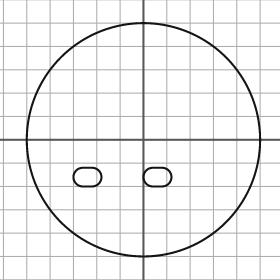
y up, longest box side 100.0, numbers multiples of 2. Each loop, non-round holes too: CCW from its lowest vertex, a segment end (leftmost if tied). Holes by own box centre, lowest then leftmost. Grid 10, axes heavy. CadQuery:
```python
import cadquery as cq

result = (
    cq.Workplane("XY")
    .moveTo(0.0, 0.0)
    .circle(50.0)
    .moveTo(-26.0, -20.0)
    .lineTo(-22.0, -20.0)
    .threePointArc((-18.0, -16.0), (-22.0, -12.0))
    .lineTo(-26.0, -12.0)
    .threePointArc((-30.0, -16.0), (-26.0, -20.0))
    .close()
    .moveTo(4.0, -20.0)
    .lineTo(8.0, -20.0)
    .threePointArc((12.0, -16.0), (8.0, -12.0))
    .lineTo(4.0, -12.0)
    .threePointArc((0.0, -16.0), (4.0, -20.0))
    .close()
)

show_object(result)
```